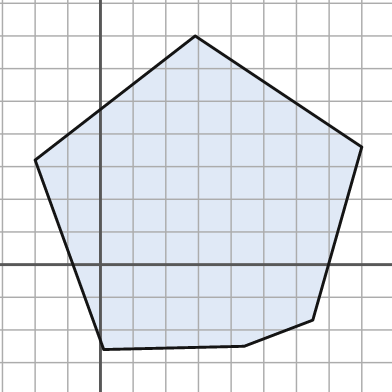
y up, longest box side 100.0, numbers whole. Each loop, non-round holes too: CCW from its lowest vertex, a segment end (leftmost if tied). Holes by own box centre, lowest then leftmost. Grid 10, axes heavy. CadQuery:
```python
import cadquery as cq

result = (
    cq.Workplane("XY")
    .moveTo(1.0, -26.0)
    .lineTo(44.0, -25.0)
    .lineTo(65.0, -17.0)
    .lineTo(80.0, 36.0)
    .lineTo(29.0, 70.0)
    .lineTo(-20.0, 32.0)
    .close()
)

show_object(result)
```